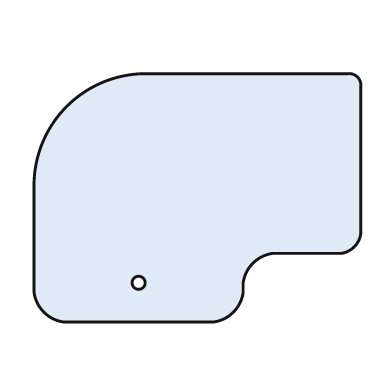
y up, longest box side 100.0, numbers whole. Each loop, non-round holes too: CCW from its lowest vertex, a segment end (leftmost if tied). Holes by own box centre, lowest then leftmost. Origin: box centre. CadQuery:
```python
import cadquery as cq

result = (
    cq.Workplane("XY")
    .moveTo(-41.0, -38.0)
    .lineTo(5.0, -38.0)
    .threePointArc((11.0, -35.0), (14.0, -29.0))
    .lineTo(14.0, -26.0)
    .threePointArc((17.0, -20.0), (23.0, -17.0))
    .lineTo(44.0, -17.0)
    .threePointArc((48.0, -15.0), (50.0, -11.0))
    .lineTo(50.0, 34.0)
    .threePointArc((49.0, 37.0), (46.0, 38.0))
    .lineTo(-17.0, 38.0)
    .threePointArc((-40.0, 28.0), (-50.0, 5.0))
    .lineTo(-50.0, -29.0)
    .threePointArc((-47.0, -35.0), (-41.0, -38.0))
    .close()
    .moveTo(-18.0, -26.0)
    .circle(2.0)
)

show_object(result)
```